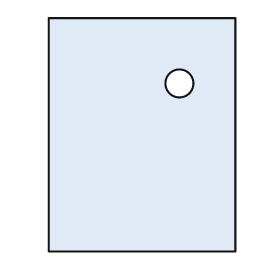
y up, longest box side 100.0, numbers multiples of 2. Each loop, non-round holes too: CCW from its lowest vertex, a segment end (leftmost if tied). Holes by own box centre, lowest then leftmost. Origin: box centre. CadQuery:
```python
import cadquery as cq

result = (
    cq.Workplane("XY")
    .moveTo(-40.0, -50.0)
    .lineTo(40.0, -50.0)
    .lineTo(40.0, 50.0)
    .lineTo(-40.0, 50.0)
    .close()
    .moveTo(16.0, 22.0)
    .circle(6.0)
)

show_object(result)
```